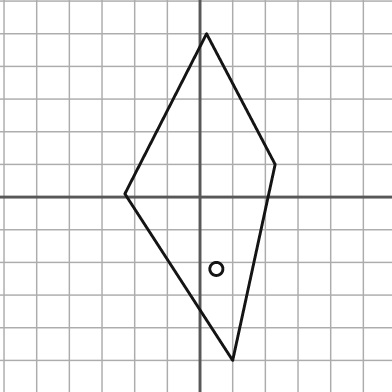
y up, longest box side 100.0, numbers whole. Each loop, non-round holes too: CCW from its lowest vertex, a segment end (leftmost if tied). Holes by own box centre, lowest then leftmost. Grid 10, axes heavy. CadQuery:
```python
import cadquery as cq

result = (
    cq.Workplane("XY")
    .moveTo(10.0, -50.0)
    .lineTo(23.0, 10.0)
    .lineTo(2.0, 50.0)
    .lineTo(-23.0, 1.0)
    .close()
    .moveTo(5.0, -22.0)
    .circle(2.0)
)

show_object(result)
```